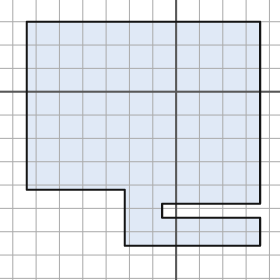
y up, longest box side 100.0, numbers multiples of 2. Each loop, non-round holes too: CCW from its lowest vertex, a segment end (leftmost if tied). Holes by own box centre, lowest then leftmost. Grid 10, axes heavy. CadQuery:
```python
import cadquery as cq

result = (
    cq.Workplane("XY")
    .moveTo(-22.0, -66.0)
    .lineTo(36.0, -66.0)
    .lineTo(36.0, -54.0)
    .lineTo(-6.0, -54.0)
    .lineTo(-6.0, -48.0)
    .lineTo(36.0, -48.0)
    .lineTo(36.0, 30.0)
    .lineTo(-64.0, 30.0)
    .lineTo(-64.0, -42.0)
    .lineTo(-22.0, -42.0)
    .close()
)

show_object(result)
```